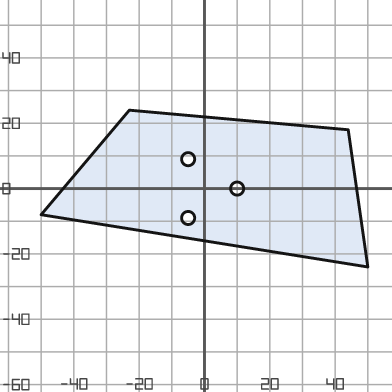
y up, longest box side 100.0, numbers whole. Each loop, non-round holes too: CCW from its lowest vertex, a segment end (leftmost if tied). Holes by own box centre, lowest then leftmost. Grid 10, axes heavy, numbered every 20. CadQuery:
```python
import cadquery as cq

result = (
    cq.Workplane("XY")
    .moveTo(50.0, -24.0)
    .lineTo(44.0, 18.0)
    .lineTo(-23.0, 24.0)
    .lineTo(-50.0, -8.0)
    .close()
    .moveTo(-5.0, -9.0)
    .circle(2.0)
    .moveTo(10.0, 0.0)
    .circle(2.0)
    .moveTo(-5.0, 9.0)
    .circle(2.0)
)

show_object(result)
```